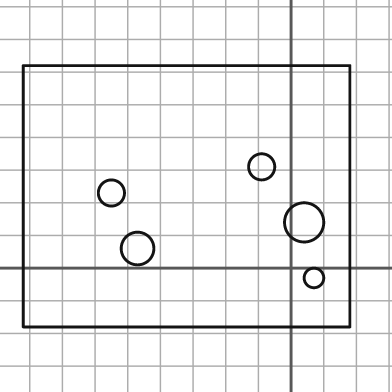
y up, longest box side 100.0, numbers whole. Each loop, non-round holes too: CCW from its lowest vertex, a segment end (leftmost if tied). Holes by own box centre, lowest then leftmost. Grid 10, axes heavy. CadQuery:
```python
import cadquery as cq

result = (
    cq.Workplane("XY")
    .moveTo(-82.0, -18.0)
    .lineTo(18.0, -18.0)
    .lineTo(18.0, 62.0)
    .lineTo(-82.0, 62.0)
    .close()
    .moveTo(7.0, -3.0)
    .circle(3.0)
    .moveTo(-47.0, 6.0)
    .circle(5.0)
    .moveTo(4.0, 14.0)
    .circle(6.0)
    .moveTo(-55.0, 23.0)
    .circle(4.0)
    .moveTo(-9.0, 31.0)
    .circle(4.0)
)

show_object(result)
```